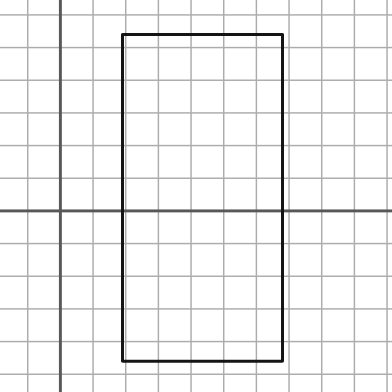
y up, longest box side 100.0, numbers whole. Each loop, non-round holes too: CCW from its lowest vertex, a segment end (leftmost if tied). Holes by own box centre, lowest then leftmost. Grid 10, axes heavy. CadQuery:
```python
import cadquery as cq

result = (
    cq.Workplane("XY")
    .moveTo(19.0, -46.0)
    .lineTo(68.0, -46.0)
    .lineTo(68.0, 54.0)
    .lineTo(19.0, 54.0)
    .close()
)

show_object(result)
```